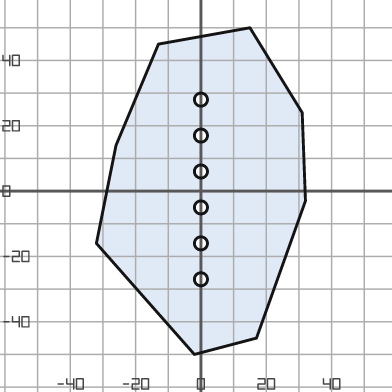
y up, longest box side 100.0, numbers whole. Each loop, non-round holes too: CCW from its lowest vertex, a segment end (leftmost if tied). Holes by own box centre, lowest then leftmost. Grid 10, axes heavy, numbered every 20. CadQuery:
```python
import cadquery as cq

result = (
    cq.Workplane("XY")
    .moveTo(-2.0, -50.0)
    .lineTo(17.0, -45.0)
    .lineTo(32.0, -3.0)
    .lineTo(31.0, 24.0)
    .lineTo(15.0, 50.0)
    .lineTo(-13.0, 45.0)
    .lineTo(-26.0, 14.0)
    .lineTo(-32.0, -16.0)
    .close()
    .moveTo(0.0, -27.0)
    .circle(2.0)
    .moveTo(0.0, -16.0)
    .circle(2.0)
    .moveTo(0.0, -5.0)
    .circle(2.0)
    .moveTo(0.0, 6.0)
    .circle(2.0)
    .moveTo(0.0, 17.0)
    .circle(2.0)
    .moveTo(0.0, 28.0)
    .circle(2.0)
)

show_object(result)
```